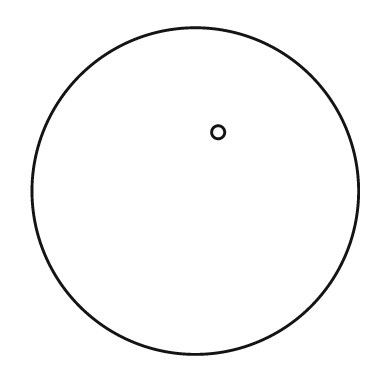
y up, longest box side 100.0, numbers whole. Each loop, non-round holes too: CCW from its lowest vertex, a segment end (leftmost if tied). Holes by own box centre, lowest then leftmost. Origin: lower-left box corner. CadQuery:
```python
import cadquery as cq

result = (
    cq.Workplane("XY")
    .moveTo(50.0, 50.0)
    .circle(50.0)
    .moveTo(57.0, 68.0)
    .circle(2.0)
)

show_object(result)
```